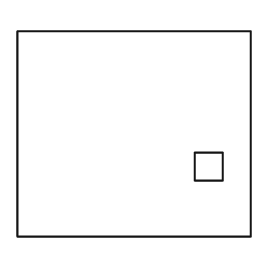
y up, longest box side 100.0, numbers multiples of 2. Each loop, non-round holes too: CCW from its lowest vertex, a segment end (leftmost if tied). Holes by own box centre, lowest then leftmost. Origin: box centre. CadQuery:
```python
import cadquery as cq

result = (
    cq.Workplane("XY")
    .moveTo(-50.0, -44.0)
    .lineTo(50.0, -44.0)
    .lineTo(50.0, 44.0)
    .lineTo(-50.0, 44.0)
    .close()
    .moveTo(26.0, -20.0)
    .lineTo(38.0, -20.0)
    .lineTo(38.0, -8.0)
    .lineTo(26.0, -8.0)
    .close()
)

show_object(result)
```